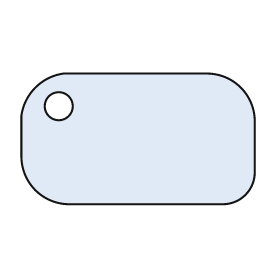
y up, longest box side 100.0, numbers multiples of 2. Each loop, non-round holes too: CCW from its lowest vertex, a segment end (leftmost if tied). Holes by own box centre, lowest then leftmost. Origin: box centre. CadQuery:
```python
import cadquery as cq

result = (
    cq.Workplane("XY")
    .moveTo(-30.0, -28.0)
    .lineTo(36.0, -28.0)
    .threePointArc((46.0, -24.0), (50.0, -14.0))
    .lineTo(50.0, 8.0)
    .threePointArc((44.0, 22.0), (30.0, 28.0))
    .lineTo(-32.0, 28.0)
    .threePointArc((-44.0, 22.0), (-50.0, 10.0))
    .lineTo(-50.0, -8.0)
    .threePointArc((-44.0, -22.0), (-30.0, -28.0))
    .close()
    .moveTo(-34.0, 14.0)
    .circle(6.0)
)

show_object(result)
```